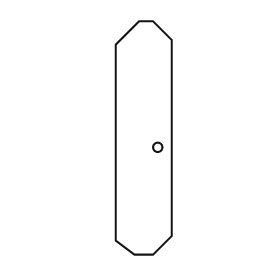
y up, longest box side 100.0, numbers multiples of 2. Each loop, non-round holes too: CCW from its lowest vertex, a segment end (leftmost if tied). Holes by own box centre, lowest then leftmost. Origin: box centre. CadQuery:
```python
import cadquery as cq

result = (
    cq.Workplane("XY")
    .moveTo(-4.0, -50.0)
    .lineTo(4.0, -50.0)
    .lineTo(12.0, -42.0)
    .lineTo(12.0, 42.0)
    .lineTo(4.0, 50.0)
    .lineTo(-2.0, 50.0)
    .lineTo(-12.0, 40.0)
    .lineTo(-12.0, -44.0)
    .close()
    .moveTo(6.0, -4.0)
    .circle(2.0)
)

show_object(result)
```